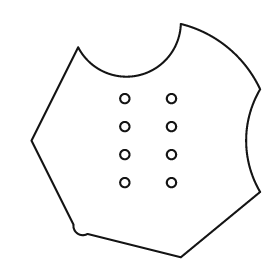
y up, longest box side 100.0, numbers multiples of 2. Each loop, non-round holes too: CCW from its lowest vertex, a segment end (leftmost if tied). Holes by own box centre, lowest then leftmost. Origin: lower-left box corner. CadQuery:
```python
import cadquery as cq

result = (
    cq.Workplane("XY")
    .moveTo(64.0, 0.0)
    .lineTo(98.0, 28.0)
    .threePointArc((92.0, 50.0), (98.0, 72.0))
    .threePointArc((84.0, 90.0), (64.0, 100.0))
    .threePointArc((46.0, 78.0), (20.0, 90.0))
    .lineTo(0.0, 50.0)
    .lineTo(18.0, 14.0)
    .threePointArc((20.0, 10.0), (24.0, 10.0))
    .close()
    .moveTo(40.0, 32.0)
    .circle(2.0)
    .moveTo(60.0, 32.0)
    .circle(2.0)
    .moveTo(40.0, 44.0)
    .circle(2.0)
    .moveTo(60.0, 44.0)
    .circle(2.0)
    .moveTo(40.0, 56.0)
    .circle(2.0)
    .moveTo(60.0, 56.0)
    .circle(2.0)
    .moveTo(40.0, 68.0)
    .circle(2.0)
    .moveTo(60.0, 68.0)
    .circle(2.0)
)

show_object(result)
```